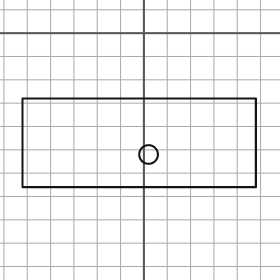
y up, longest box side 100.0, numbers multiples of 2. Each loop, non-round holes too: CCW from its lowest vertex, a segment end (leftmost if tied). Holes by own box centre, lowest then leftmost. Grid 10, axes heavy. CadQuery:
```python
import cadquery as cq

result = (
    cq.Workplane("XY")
    .moveTo(-52.0, -66.0)
    .lineTo(48.0, -66.0)
    .lineTo(48.0, -28.0)
    .lineTo(-52.0, -28.0)
    .close()
    .moveTo(2.0, -52.0)
    .circle(4.0)
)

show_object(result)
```